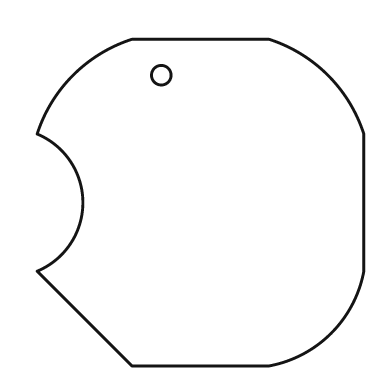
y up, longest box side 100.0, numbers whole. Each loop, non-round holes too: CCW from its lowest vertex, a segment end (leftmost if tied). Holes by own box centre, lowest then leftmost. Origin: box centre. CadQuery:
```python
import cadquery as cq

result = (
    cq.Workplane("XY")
    .moveTo(-21.0, -50.0)
    .lineTo(21.0, -50.0)
    .threePointArc((40.0, -40.0), (50.0, -21.0))
    .lineTo(50.0, 21.0)
    .threePointArc((39.0, 39.0), (21.0, 50.0))
    .lineTo(-21.0, 50.0)
    .threePointArc((-39.0, 39.0), (-50.0, 21.0))
    .threePointArc((-36.0, 0.0), (-50.0, -21.0))
    .close()
    .moveTo(-12.0, 39.0)
    .circle(3.0)
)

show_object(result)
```